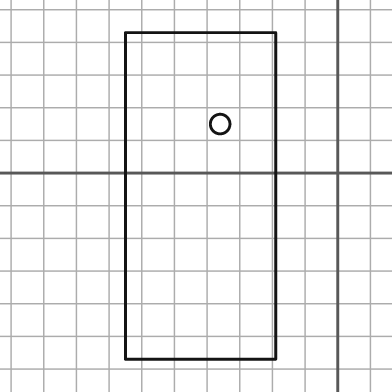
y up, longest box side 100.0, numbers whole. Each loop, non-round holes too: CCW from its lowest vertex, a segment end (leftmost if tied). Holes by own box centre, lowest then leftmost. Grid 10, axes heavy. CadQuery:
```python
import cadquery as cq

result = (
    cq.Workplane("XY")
    .moveTo(-65.0, -57.0)
    .lineTo(-19.0, -57.0)
    .lineTo(-19.0, 43.0)
    .lineTo(-65.0, 43.0)
    .close()
    .moveTo(-36.0, 15.0)
    .circle(3.0)
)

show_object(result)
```